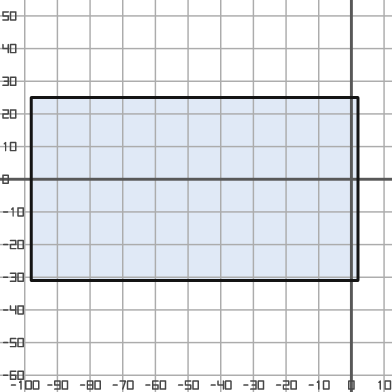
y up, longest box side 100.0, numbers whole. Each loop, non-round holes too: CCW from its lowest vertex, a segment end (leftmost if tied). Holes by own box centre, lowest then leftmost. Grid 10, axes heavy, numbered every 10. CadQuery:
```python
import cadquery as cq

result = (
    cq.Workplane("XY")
    .moveTo(-98.0, -31.0)
    .lineTo(2.0, -31.0)
    .lineTo(2.0, 25.0)
    .lineTo(-98.0, 25.0)
    .close()
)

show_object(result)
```